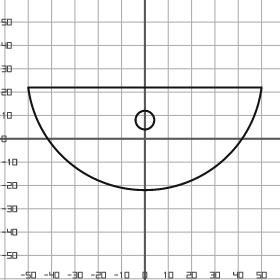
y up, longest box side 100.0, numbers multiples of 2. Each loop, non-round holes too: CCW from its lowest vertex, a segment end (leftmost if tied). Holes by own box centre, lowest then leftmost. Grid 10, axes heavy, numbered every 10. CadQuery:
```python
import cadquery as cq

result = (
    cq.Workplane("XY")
    .moveTo(-50.0, 22.0)
    .threePointArc((0.0, -22.0), (50.0, 22.0))
    .close()
    .moveTo(0.0, 8.0)
    .circle(4.0)
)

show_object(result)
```